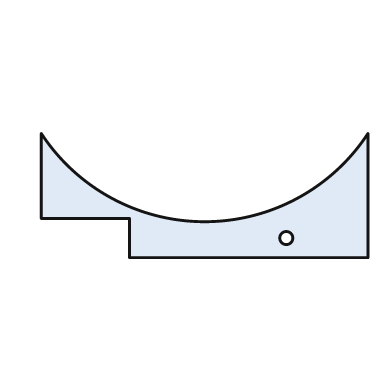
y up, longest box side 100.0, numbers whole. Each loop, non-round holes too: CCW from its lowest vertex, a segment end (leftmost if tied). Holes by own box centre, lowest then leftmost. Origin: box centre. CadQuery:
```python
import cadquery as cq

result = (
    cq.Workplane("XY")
    .moveTo(-23.0, -19.0)
    .lineTo(50.0, -19.0)
    .lineTo(50.0, 19.0)
    .threePointArc((0.0, -8.0), (-50.0, 19.0))
    .lineTo(-50.0, -7.0)
    .lineTo(-23.0, -7.0)
    .close()
    .moveTo(25.0, -13.0)
    .circle(2.0)
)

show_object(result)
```